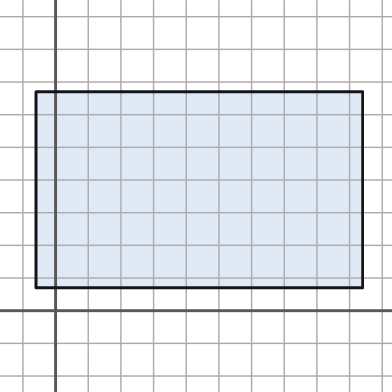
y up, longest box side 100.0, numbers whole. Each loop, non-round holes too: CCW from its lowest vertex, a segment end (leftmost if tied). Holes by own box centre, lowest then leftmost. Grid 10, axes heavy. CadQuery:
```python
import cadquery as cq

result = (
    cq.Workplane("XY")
    .moveTo(-6.0, 7.0)
    .lineTo(94.0, 7.0)
    .lineTo(94.0, 67.0)
    .lineTo(-6.0, 67.0)
    .close()
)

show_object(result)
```